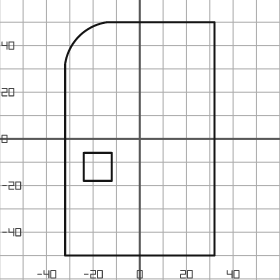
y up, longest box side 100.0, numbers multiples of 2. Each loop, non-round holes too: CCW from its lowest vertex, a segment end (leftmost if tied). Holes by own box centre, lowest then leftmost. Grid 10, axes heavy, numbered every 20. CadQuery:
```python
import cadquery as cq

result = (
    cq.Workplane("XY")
    .moveTo(-32.0, -50.0)
    .lineTo(32.0, -50.0)
    .lineTo(32.0, 50.0)
    .lineTo(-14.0, 50.0)
    .threePointArc((-26.0, 44.0), (-32.0, 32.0))
    .close()
    .moveTo(-24.0, -18.0)
    .lineTo(-12.0, -18.0)
    .lineTo(-12.0, -6.0)
    .lineTo(-24.0, -6.0)
    .close()
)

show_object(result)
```